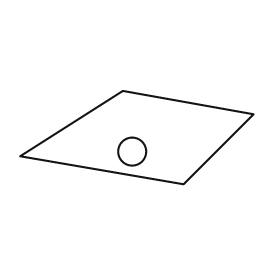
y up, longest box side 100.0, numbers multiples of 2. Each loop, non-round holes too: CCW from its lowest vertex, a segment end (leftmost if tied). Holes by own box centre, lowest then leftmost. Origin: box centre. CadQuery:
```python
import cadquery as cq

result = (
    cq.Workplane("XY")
    .moveTo(20.0, -20.0)
    .lineTo(50.0, 10.0)
    .lineTo(-6.0, 20.0)
    .lineTo(-50.0, -8.0)
    .close()
    .moveTo(-2.0, -6.0)
    .circle(6.0)
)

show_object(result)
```